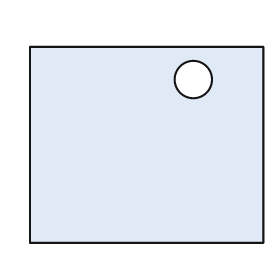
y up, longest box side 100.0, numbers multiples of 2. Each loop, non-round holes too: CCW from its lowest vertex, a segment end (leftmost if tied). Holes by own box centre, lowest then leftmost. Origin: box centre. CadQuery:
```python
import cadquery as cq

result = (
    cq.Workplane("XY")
    .moveTo(-50.0, -42.0)
    .lineTo(50.0, -42.0)
    .lineTo(50.0, 42.0)
    .lineTo(-50.0, 42.0)
    .close()
    .moveTo(20.0, 28.0)
    .circle(8.0)
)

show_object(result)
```